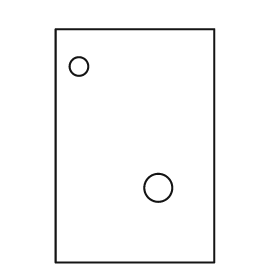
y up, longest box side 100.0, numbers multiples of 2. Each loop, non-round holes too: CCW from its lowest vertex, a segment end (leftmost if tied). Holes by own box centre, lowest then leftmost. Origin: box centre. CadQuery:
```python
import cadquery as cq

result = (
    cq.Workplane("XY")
    .moveTo(-34.0, -50.0)
    .lineTo(34.0, -50.0)
    .lineTo(34.0, 50.0)
    .lineTo(-34.0, 50.0)
    .close()
    .moveTo(10.0, -18.0)
    .circle(6.0)
    .moveTo(-24.0, 34.0)
    .circle(4.0)
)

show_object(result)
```